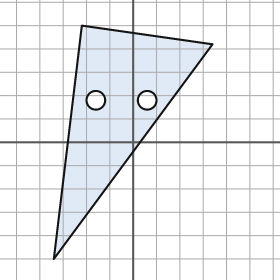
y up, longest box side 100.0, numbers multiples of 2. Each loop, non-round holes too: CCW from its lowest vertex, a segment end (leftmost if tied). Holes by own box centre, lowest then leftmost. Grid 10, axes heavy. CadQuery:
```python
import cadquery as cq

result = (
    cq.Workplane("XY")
    .moveTo(-34.0, -50.0)
    .lineTo(34.0, 42.0)
    .lineTo(-22.0, 50.0)
    .close()
    .moveTo(-16.0, 18.0)
    .circle(4.0)
    .moveTo(6.0, 18.0)
    .circle(4.0)
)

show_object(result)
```